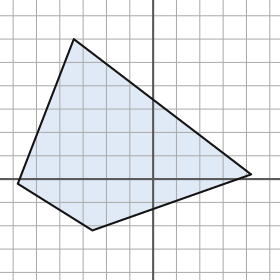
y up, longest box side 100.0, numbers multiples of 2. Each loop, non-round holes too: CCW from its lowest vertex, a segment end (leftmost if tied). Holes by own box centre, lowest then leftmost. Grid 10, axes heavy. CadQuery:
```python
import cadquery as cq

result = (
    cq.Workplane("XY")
    .moveTo(-26.0, -22.0)
    .lineTo(42.0, 2.0)
    .lineTo(-34.0, 60.0)
    .lineTo(-58.0, -2.0)
    .close()
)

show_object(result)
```